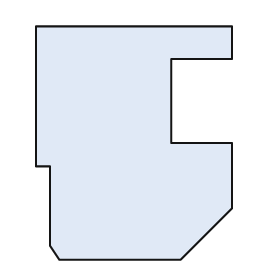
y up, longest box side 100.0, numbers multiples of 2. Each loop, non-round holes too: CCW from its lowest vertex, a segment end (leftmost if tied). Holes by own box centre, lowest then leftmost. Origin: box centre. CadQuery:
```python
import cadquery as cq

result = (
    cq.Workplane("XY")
    .moveTo(-32.0, -50.0)
    .lineTo(20.0, -50.0)
    .lineTo(42.0, -28.0)
    .lineTo(42.0, 0.0)
    .lineTo(16.0, 0.0)
    .lineTo(16.0, 36.0)
    .lineTo(42.0, 36.0)
    .lineTo(42.0, 50.0)
    .lineTo(-42.0, 50.0)
    .lineTo(-42.0, -10.0)
    .lineTo(-36.0, -10.0)
    .lineTo(-36.0, -44.0)
    .close()
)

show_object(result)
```